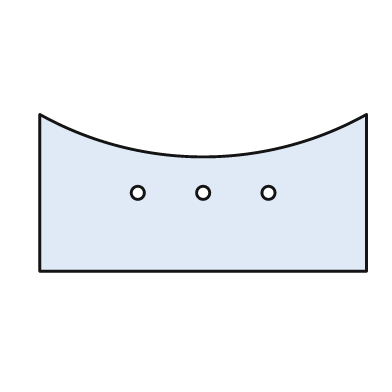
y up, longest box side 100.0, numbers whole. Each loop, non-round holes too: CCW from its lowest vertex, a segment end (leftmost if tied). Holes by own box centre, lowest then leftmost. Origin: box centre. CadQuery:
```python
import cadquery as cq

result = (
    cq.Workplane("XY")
    .moveTo(-50.0, -24.0)
    .lineTo(50.0, -24.0)
    .lineTo(50.0, 24.0)
    .threePointArc((0.0, 11.0), (-50.0, 24.0))
    .close()
    .moveTo(-20.0, 0.0)
    .circle(2.0)
    .moveTo(0.0, 0.0)
    .circle(2.0)
    .moveTo(20.0, 0.0)
    .circle(2.0)
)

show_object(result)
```